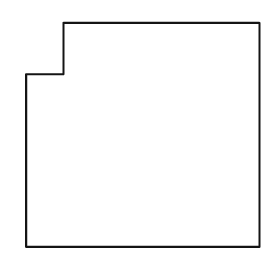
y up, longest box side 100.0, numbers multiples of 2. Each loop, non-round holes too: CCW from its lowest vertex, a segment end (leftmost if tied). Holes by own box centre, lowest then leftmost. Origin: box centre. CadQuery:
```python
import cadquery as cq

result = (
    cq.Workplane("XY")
    .moveTo(-50.0, -48.0)
    .lineTo(50.0, -48.0)
    .lineTo(50.0, 48.0)
    .lineTo(-34.0, 48.0)
    .lineTo(-34.0, 26.0)
    .lineTo(-50.0, 26.0)
    .close()
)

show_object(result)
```